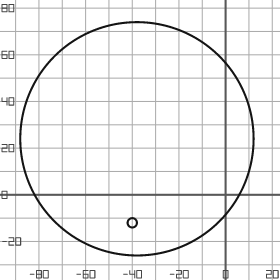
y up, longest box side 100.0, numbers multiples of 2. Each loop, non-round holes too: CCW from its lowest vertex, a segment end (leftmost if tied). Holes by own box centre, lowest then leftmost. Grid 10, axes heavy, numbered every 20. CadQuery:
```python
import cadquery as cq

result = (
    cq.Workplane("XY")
    .moveTo(-38.0, 24.0)
    .circle(50.0)
    .moveTo(-40.0, -12.0)
    .circle(2.0)
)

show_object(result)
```